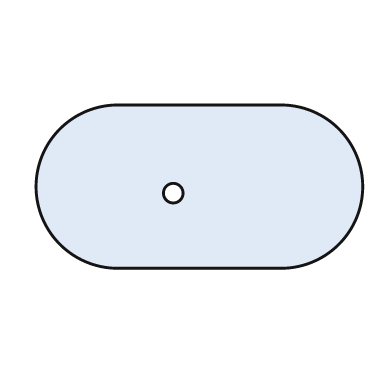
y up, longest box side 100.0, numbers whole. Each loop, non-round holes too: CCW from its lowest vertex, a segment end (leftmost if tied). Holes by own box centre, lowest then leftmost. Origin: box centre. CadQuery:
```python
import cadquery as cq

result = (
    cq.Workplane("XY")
    .moveTo(-25.0, -25.0)
    .lineTo(25.0, -25.0)
    .threePointArc((50.0, 0.0), (25.0, 25.0))
    .lineTo(-25.0, 25.0)
    .threePointArc((-50.0, 0.0), (-25.0, -25.0))
    .close()
    .moveTo(-8.0, -2.0)
    .circle(3.0)
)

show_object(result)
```